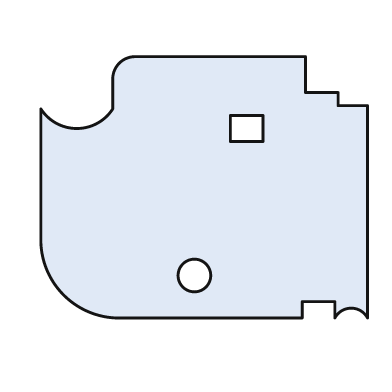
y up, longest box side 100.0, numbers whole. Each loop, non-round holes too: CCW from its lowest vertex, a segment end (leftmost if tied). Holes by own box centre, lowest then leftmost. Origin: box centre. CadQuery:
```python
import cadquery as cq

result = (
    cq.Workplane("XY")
    .moveTo(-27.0, -40.0)
    .lineTo(30.0, -40.0)
    .lineTo(30.0, -35.0)
    .lineTo(40.0, -35.0)
    .lineTo(40.0, -40.0)
    .threePointArc((45.0, -37.0), (50.0, -40.0))
    .lineTo(50.0, 25.0)
    .lineTo(41.0, 25.0)
    .lineTo(41.0, 29.0)
    .lineTo(31.0, 29.0)
    .lineTo(31.0, 40.0)
    .lineTo(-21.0, 40.0)
    .threePointArc((-26.0, 38.0), (-28.0, 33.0))
    .lineTo(-28.0, 24.0)
    .threePointArc((-39.0, 18.0), (-50.0, 24.0))
    .lineTo(-50.0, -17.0)
    .threePointArc((-43.0, -33.0), (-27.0, -40.0))
    .close()
    .moveTo(-3.0, -27.0)
    .circle(5.0)
    .moveTo(8.0, 14.0)
    .lineTo(18.0, 14.0)
    .lineTo(18.0, 22.0)
    .lineTo(8.0, 22.0)
    .close()
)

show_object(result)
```